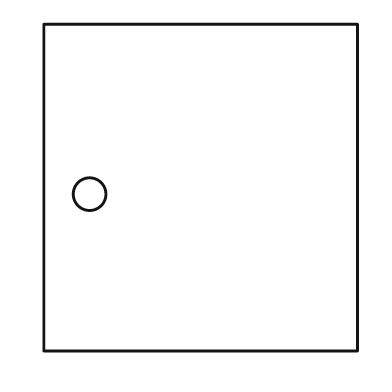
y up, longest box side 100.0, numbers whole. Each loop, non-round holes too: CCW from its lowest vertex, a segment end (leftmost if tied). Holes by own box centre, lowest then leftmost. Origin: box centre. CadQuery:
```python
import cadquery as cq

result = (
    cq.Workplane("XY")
    .moveTo(-48.0, -50.0)
    .lineTo(48.0, -50.0)
    .lineTo(48.0, 50.0)
    .lineTo(-48.0, 50.0)
    .close()
    .moveTo(-34.0, -2.0)
    .circle(5.0)
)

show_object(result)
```